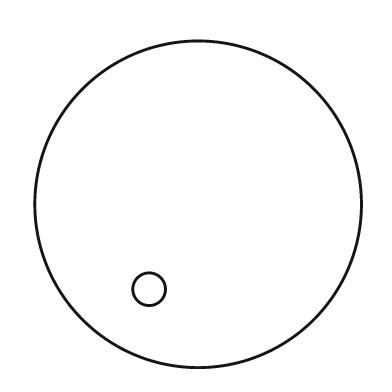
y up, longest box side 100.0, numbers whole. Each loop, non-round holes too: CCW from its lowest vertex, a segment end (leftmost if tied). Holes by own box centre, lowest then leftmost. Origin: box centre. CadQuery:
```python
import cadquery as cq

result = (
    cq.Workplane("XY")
    .moveTo(0.0, 0.0)
    .circle(50.0)
    .moveTo(-15.0, -26.0)
    .circle(5.0)
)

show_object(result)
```